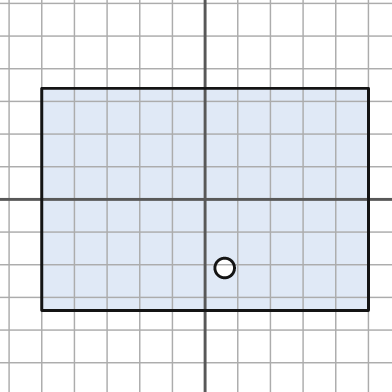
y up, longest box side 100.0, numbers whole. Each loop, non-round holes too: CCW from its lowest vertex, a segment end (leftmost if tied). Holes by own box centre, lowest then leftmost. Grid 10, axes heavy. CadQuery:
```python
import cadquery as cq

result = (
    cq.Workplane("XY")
    .moveTo(-50.0, -34.0)
    .lineTo(50.0, -34.0)
    .lineTo(50.0, 34.0)
    .lineTo(-50.0, 34.0)
    .close()
    .moveTo(6.0, -21.0)
    .circle(3.0)
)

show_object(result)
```